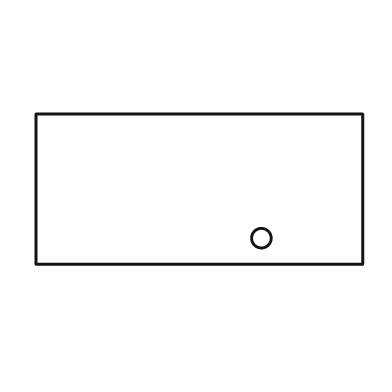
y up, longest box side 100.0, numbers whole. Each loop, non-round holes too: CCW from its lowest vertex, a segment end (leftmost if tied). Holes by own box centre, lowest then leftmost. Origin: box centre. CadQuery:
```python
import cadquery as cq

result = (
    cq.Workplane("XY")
    .moveTo(-50.0, -23.0)
    .lineTo(50.0, -23.0)
    .lineTo(50.0, 23.0)
    .lineTo(-50.0, 23.0)
    .close()
    .moveTo(19.0, -15.0)
    .circle(3.0)
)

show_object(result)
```